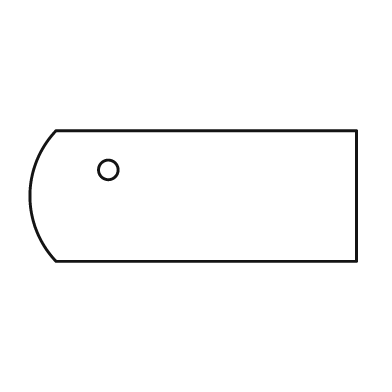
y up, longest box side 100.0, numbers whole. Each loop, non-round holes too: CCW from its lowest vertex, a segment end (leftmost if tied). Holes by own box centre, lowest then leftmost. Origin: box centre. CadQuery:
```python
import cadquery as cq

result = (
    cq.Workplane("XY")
    .moveTo(-42.0, -20.0)
    .lineTo(50.0, -20.0)
    .lineTo(50.0, 20.0)
    .lineTo(-42.0, 20.0)
    .threePointArc((-50.0, 0.0), (-42.0, -20.0))
    .close()
    .moveTo(-26.0, 8.0)
    .circle(3.0)
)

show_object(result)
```